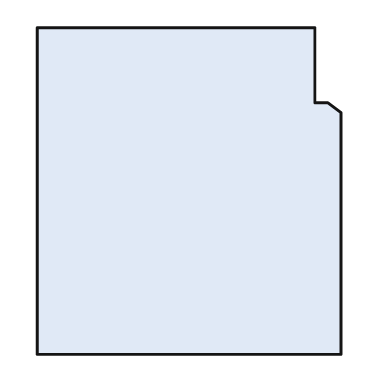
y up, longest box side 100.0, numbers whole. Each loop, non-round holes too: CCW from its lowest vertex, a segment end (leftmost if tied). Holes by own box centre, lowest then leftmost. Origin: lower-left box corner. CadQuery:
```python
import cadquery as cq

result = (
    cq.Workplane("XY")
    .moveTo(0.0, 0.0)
    .lineTo(93.0, 0.0)
    .lineTo(93.0, 74.0)
    .lineTo(89.0, 77.0)
    .lineTo(85.0, 77.0)
    .lineTo(85.0, 100.0)
    .lineTo(0.0, 100.0)
    .close()
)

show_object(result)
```